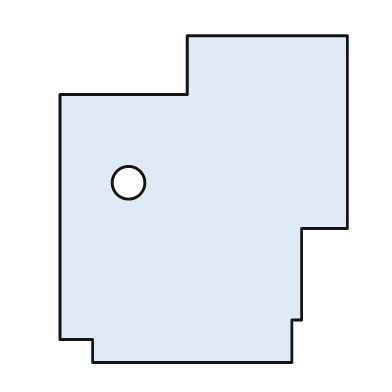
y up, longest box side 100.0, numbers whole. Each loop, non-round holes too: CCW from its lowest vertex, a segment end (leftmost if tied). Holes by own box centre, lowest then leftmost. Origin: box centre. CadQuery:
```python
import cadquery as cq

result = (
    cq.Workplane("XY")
    .moveTo(-34.0, -50.0)
    .lineTo(27.0, -50.0)
    .lineTo(27.0, -37.0)
    .lineTo(30.0, -37.0)
    .lineTo(30.0, -9.0)
    .lineTo(44.0, -9.0)
    .lineTo(44.0, 50.0)
    .lineTo(-5.0, 50.0)
    .lineTo(-5.0, 32.0)
    .lineTo(-44.0, 32.0)
    .lineTo(-44.0, -43.0)
    .lineTo(-34.0, -43.0)
    .close()
    .moveTo(-23.0, 5.0)
    .circle(5.0)
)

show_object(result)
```